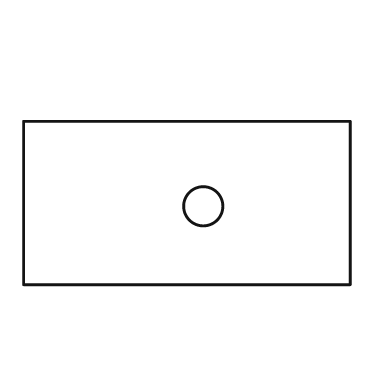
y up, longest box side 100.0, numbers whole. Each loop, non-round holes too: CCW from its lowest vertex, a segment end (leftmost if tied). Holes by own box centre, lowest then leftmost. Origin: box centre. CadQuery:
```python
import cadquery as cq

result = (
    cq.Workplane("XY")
    .moveTo(-50.0, -25.0)
    .lineTo(50.0, -25.0)
    .lineTo(50.0, 25.0)
    .lineTo(-50.0, 25.0)
    .close()
    .moveTo(5.0, -1.0)
    .circle(6.0)
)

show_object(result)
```